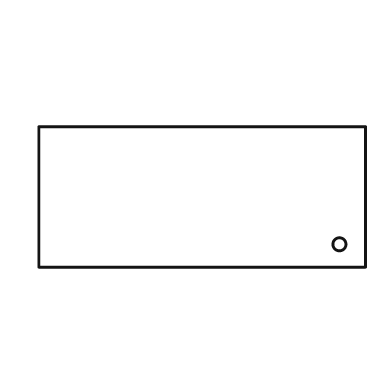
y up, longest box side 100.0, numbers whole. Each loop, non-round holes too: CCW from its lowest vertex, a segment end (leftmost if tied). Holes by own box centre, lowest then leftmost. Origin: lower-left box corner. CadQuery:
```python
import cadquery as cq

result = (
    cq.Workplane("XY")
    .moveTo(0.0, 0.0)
    .lineTo(100.0, 0.0)
    .lineTo(100.0, 43.0)
    .lineTo(0.0, 43.0)
    .close()
    .moveTo(92.0, 7.0)
    .circle(2.0)
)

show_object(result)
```